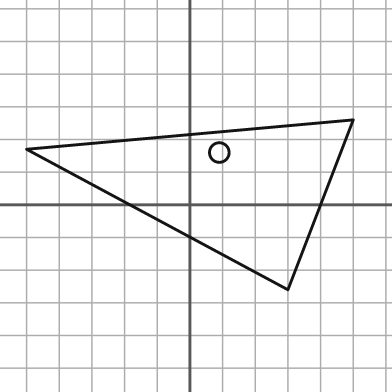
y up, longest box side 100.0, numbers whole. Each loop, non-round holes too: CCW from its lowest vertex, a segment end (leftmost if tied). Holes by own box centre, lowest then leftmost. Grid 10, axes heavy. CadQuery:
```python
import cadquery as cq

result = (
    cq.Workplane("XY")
    .moveTo(30.0, -26.0)
    .lineTo(50.0, 26.0)
    .lineTo(-50.0, 17.0)
    .close()
    .moveTo(9.0, 16.0)
    .circle(3.0)
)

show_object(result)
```